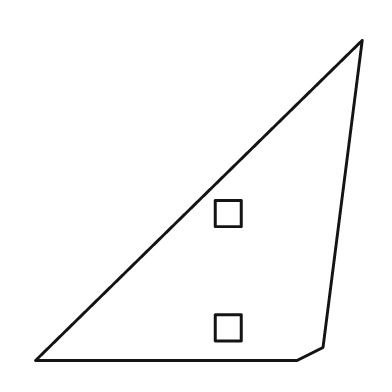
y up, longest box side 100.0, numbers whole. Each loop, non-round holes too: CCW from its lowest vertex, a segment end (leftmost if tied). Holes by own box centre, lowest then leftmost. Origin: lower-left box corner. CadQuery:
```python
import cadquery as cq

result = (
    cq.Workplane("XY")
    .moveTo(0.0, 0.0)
    .lineTo(80.0, 0.0)
    .lineTo(88.0, 4.0)
    .lineTo(100.0, 98.0)
    .close()
    .moveTo(55.0, 6.0)
    .lineTo(63.0, 6.0)
    .lineTo(63.0, 14.0)
    .lineTo(55.0, 14.0)
    .close()
    .moveTo(55.0, 41.0)
    .lineTo(63.0, 41.0)
    .lineTo(63.0, 49.0)
    .lineTo(55.0, 49.0)
    .close()
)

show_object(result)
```